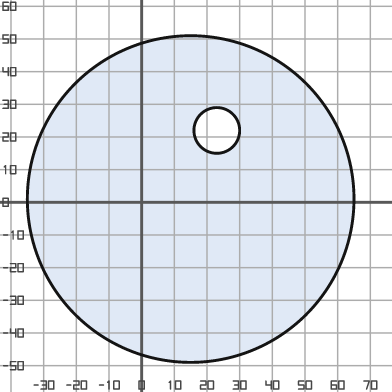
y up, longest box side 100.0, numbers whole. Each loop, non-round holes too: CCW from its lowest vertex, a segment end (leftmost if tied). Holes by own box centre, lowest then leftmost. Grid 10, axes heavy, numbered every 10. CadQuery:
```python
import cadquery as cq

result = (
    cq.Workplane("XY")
    .moveTo(15.0, 1.0)
    .circle(50.0)
    .moveTo(23.0, 22.0)
    .circle(7.0)
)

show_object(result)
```